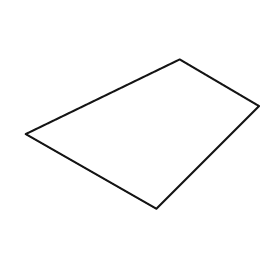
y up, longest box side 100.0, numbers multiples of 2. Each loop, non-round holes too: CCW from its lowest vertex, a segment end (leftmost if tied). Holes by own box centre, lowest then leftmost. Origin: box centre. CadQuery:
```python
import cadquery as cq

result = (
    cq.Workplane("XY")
    .moveTo(6.0, -32.0)
    .lineTo(50.0, 12.0)
    .lineTo(16.0, 32.0)
    .lineTo(-50.0, 0.0)
    .close()
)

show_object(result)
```